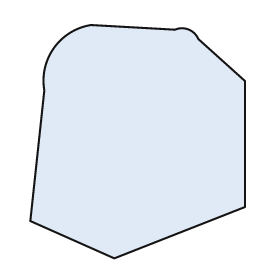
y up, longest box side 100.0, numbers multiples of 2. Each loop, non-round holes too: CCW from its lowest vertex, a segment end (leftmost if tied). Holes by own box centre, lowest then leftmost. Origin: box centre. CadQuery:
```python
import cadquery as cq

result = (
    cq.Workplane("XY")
    .moveTo(-10.0, -50.0)
    .lineTo(46.0, -28.0)
    .lineTo(46.0, 26.0)
    .lineTo(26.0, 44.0)
    .threePointArc((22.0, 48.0), (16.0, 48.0))
    .lineTo(-20.0, 50.0)
    .threePointArc((-36.0, 40.0), (-40.0, 22.0))
    .lineTo(-46.0, -34.0)
    .close()
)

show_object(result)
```